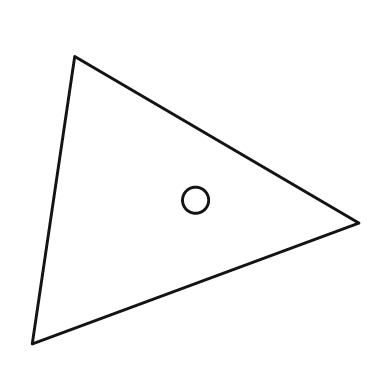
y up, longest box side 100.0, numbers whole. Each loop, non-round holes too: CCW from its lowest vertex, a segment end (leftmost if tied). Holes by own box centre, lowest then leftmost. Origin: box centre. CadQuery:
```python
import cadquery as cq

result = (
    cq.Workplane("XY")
    .moveTo(-50.0, -44.0)
    .lineTo(50.0, -7.0)
    .lineTo(-37.0, 44.0)
    .close()
    .moveTo(0.0, 0.0)
    .circle(4.0)
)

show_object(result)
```